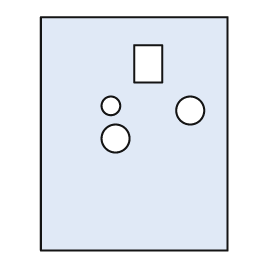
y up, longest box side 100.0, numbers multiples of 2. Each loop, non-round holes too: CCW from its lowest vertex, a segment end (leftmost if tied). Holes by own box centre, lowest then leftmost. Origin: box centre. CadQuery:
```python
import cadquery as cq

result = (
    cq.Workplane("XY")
    .moveTo(-40.0, -50.0)
    .lineTo(40.0, -50.0)
    .lineTo(40.0, 50.0)
    .lineTo(-40.0, 50.0)
    .close()
    .moveTo(-8.0, -2.0)
    .circle(6.0)
    .moveTo(24.0, 10.0)
    .circle(6.0)
    .moveTo(-10.0, 12.0)
    .circle(4.0)
    .moveTo(0.0, 22.0)
    .lineTo(12.0, 22.0)
    .lineTo(12.0, 38.0)
    .lineTo(0.0, 38.0)
    .close()
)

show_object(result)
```